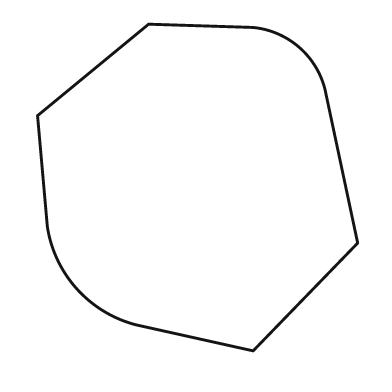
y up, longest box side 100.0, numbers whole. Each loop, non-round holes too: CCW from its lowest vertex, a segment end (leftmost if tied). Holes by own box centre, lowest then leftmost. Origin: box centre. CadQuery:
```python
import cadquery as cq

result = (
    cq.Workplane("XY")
    .moveTo(17.0, -50.0)
    .lineTo(49.0, -17.0)
    .lineTo(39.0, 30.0)
    .threePointArc((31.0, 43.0), (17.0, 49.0))
    .lineTo(-15.0, 50.0)
    .lineTo(-49.0, 22.0)
    .lineTo(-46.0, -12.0)
    .threePointArc((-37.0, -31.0), (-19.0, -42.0))
    .close()
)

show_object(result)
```